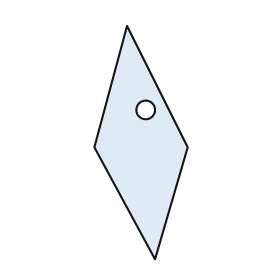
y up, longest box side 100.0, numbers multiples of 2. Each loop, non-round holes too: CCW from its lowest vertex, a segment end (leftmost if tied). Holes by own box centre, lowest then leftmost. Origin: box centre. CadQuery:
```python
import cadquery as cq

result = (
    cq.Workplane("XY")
    .moveTo(6.0, -50.0)
    .lineTo(20.0, -2.0)
    .lineTo(-6.0, 50.0)
    .lineTo(-20.0, -2.0)
    .close()
    .moveTo(2.0, 14.0)
    .circle(4.0)
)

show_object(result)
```